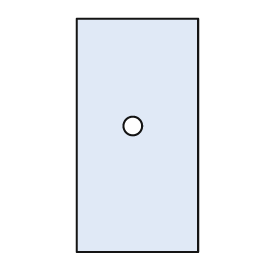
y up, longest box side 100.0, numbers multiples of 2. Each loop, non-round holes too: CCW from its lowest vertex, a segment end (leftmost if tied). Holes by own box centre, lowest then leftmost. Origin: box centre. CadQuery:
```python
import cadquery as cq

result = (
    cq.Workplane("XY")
    .moveTo(-26.0, -50.0)
    .lineTo(26.0, -50.0)
    .lineTo(26.0, 50.0)
    .lineTo(-26.0, 50.0)
    .close()
    .moveTo(-2.0, 4.0)
    .circle(4.0)
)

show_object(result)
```